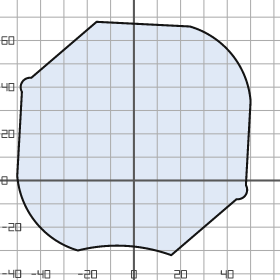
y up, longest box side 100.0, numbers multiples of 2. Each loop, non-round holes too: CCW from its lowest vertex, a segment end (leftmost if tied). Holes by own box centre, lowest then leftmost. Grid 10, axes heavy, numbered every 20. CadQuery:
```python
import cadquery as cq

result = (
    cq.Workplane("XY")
    .moveTo(16.0, -32.0)
    .lineTo(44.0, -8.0)
    .threePointArc((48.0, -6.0), (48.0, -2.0))
    .lineTo(50.0, 34.0)
    .threePointArc((42.0, 54.0), (24.0, 66.0))
    .lineTo(-16.0, 68.0)
    .lineTo(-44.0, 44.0)
    .threePointArc((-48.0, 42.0), (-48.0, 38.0))
    .lineTo(-50.0, 2.0)
    .threePointArc((-42.0, -18.0), (-24.0, -30.0))
    .threePointArc((-4.0, -28.0), (16.0, -32.0))
    .close()
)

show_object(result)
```